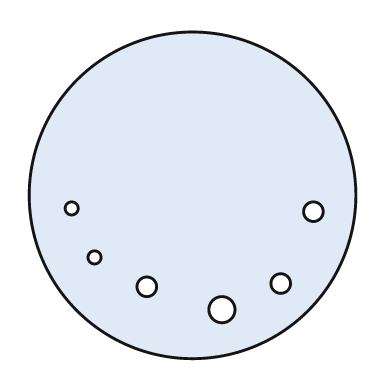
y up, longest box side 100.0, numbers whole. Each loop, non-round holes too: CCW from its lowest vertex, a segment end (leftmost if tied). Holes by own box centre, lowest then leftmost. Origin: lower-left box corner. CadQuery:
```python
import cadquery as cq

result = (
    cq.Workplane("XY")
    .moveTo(50.0, 50.0)
    .circle(50.0)
    .moveTo(59.0, 15.0)
    .circle(4.0)
    .moveTo(36.0, 22.0)
    .circle(3.0)
    .moveTo(77.0, 23.0)
    .circle(3.0)
    .moveTo(20.0, 31.0)
    .circle(2.0)
    .moveTo(87.0, 45.0)
    .circle(3.0)
    .moveTo(13.0, 46.0)
    .circle(2.0)
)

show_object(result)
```